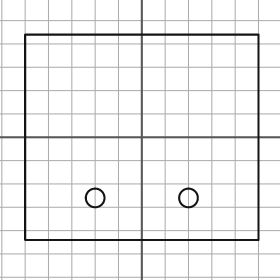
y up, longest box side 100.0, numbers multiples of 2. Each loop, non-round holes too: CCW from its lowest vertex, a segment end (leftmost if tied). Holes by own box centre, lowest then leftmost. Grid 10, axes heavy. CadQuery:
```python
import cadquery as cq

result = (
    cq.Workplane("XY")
    .moveTo(-50.0, -44.0)
    .lineTo(50.0, -44.0)
    .lineTo(50.0, 44.0)
    .lineTo(-50.0, 44.0)
    .close()
    .moveTo(-20.0, -26.0)
    .circle(4.0)
    .moveTo(20.0, -26.0)
    .circle(4.0)
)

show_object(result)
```